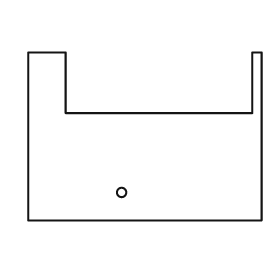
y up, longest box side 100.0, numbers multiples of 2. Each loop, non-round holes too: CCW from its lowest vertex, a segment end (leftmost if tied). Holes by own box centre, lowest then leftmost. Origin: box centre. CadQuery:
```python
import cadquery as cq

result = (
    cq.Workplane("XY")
    .moveTo(-50.0, -36.0)
    .lineTo(50.0, -36.0)
    .lineTo(50.0, 36.0)
    .lineTo(46.0, 36.0)
    .lineTo(46.0, 10.0)
    .lineTo(-34.0, 10.0)
    .lineTo(-34.0, 36.0)
    .lineTo(-50.0, 36.0)
    .close()
    .moveTo(-10.0, -24.0)
    .circle(2.0)
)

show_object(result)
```